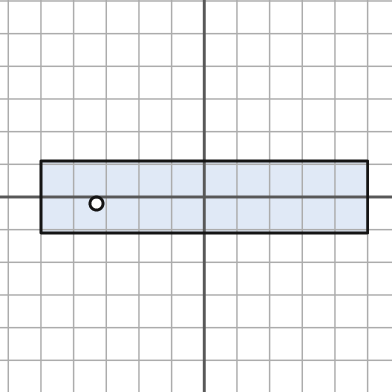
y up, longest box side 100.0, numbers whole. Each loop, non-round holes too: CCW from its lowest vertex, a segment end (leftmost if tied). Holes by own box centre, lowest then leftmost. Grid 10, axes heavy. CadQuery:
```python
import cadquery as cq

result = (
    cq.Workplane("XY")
    .moveTo(-50.0, -11.0)
    .lineTo(50.0, -11.0)
    .lineTo(50.0, 11.0)
    .lineTo(-50.0, 11.0)
    .close()
    .moveTo(-33.0, -2.0)
    .circle(2.0)
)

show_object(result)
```